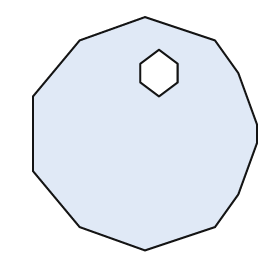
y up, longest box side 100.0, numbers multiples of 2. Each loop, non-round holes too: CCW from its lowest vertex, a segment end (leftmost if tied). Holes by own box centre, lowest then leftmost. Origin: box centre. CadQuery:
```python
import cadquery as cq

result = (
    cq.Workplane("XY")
    .moveTo(0.0, -50.0)
    .lineTo(30.0, -40.0)
    .lineTo(40.0, -26.0)
    .lineTo(48.0, -4.0)
    .lineTo(48.0, 4.0)
    .lineTo(40.0, 26.0)
    .lineTo(30.0, 40.0)
    .lineTo(0.0, 50.0)
    .lineTo(-28.0, 40.0)
    .lineTo(-48.0, 16.0)
    .lineTo(-48.0, -16.0)
    .lineTo(-28.0, -40.0)
    .close()
    .moveTo(6.0, 16.0)
    .lineTo(14.0, 22.0)
    .lineTo(14.0, 30.0)
    .lineTo(6.0, 36.0)
    .lineTo(-2.0, 30.0)
    .lineTo(-2.0, 22.0)
    .close()
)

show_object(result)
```